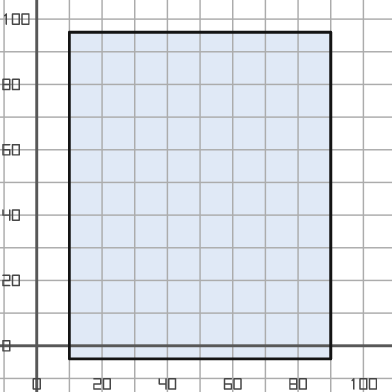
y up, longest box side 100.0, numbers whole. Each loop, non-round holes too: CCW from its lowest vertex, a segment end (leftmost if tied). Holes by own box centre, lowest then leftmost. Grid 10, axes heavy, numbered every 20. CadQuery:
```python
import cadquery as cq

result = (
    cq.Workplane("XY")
    .moveTo(10.0, -4.0)
    .lineTo(90.0, -4.0)
    .lineTo(90.0, 96.0)
    .lineTo(10.0, 96.0)
    .close()
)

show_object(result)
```